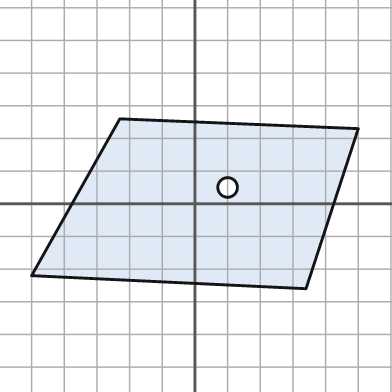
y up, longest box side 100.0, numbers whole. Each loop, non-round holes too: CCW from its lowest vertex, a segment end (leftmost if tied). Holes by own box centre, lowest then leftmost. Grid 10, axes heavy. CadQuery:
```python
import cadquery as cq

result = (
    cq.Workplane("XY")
    .moveTo(34.0, -26.0)
    .lineTo(50.0, 23.0)
    .lineTo(-23.0, 26.0)
    .lineTo(-50.0, -22.0)
    .close()
    .moveTo(10.0, 5.0)
    .circle(3.0)
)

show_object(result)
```